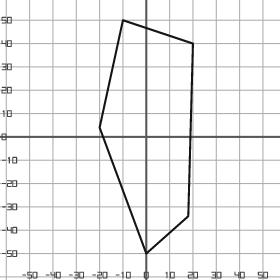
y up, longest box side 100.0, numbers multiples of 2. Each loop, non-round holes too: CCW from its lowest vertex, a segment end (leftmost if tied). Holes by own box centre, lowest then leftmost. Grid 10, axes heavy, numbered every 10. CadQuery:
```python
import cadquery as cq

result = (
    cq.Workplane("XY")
    .moveTo(0.0, -50.0)
    .lineTo(18.0, -34.0)
    .lineTo(20.0, 40.0)
    .lineTo(-10.0, 50.0)
    .lineTo(-20.0, 4.0)
    .close()
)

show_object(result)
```